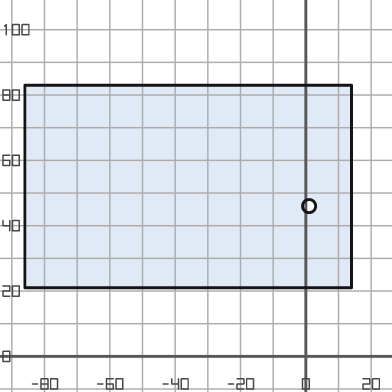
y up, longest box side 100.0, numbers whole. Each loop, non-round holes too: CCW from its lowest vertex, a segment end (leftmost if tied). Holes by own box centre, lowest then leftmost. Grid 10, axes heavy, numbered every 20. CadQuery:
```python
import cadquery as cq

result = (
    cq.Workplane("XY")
    .moveTo(-86.0, 21.0)
    .lineTo(14.0, 21.0)
    .lineTo(14.0, 83.0)
    .lineTo(-86.0, 83.0)
    .close()
    .moveTo(1.0, 46.0)
    .circle(2.0)
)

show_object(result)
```